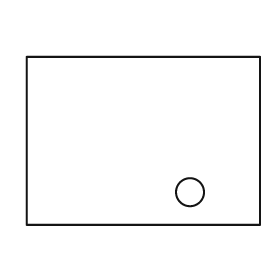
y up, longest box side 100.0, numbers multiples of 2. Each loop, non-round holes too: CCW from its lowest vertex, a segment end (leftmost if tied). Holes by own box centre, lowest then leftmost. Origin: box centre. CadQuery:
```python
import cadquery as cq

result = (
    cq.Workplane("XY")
    .moveTo(-50.0, -36.0)
    .lineTo(50.0, -36.0)
    .lineTo(50.0, 36.0)
    .lineTo(-50.0, 36.0)
    .close()
    .moveTo(20.0, -22.0)
    .circle(6.0)
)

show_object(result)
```